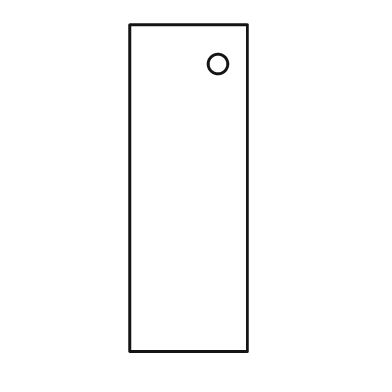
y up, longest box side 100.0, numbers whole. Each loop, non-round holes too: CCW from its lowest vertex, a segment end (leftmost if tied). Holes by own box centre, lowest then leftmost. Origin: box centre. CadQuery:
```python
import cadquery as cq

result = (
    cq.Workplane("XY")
    .moveTo(-18.0, -50.0)
    .lineTo(18.0, -50.0)
    .lineTo(18.0, 50.0)
    .lineTo(-18.0, 50.0)
    .close()
    .moveTo(9.0, 38.0)
    .circle(3.0)
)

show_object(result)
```